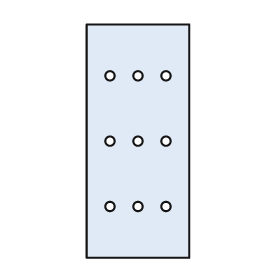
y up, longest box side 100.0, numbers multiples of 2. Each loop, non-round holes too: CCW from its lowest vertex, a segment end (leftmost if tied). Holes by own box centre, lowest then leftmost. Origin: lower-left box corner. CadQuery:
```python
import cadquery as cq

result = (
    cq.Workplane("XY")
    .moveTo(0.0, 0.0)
    .lineTo(44.0, 0.0)
    .lineTo(44.0, 100.0)
    .lineTo(0.0, 100.0)
    .close()
    .moveTo(10.0, 22.0)
    .circle(2.0)
    .moveTo(22.0, 22.0)
    .circle(2.0)
    .moveTo(34.0, 22.0)
    .circle(2.0)
    .moveTo(10.0, 50.0)
    .circle(2.0)
    .moveTo(22.0, 50.0)
    .circle(2.0)
    .moveTo(34.0, 50.0)
    .circle(2.0)
    .moveTo(10.0, 78.0)
    .circle(2.0)
    .moveTo(22.0, 78.0)
    .circle(2.0)
    .moveTo(34.0, 78.0)
    .circle(2.0)
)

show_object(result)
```